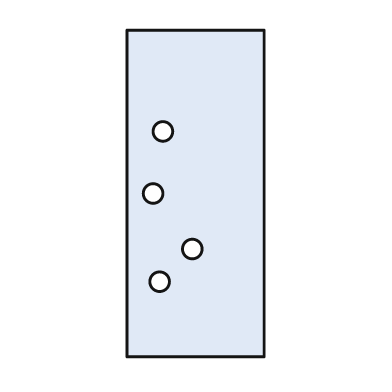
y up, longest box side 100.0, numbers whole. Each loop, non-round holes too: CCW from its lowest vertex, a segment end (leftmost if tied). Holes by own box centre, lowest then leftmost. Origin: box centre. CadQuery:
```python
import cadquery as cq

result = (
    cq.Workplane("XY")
    .moveTo(-21.0, -50.0)
    .lineTo(21.0, -50.0)
    .lineTo(21.0, 50.0)
    .lineTo(-21.0, 50.0)
    .close()
    .moveTo(-11.0, -27.0)
    .circle(3.0)
    .moveTo(-1.0, -17.0)
    .circle(3.0)
    .moveTo(-13.0, 0.0)
    .circle(3.0)
    .moveTo(-10.0, 19.0)
    .circle(3.0)
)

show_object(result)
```